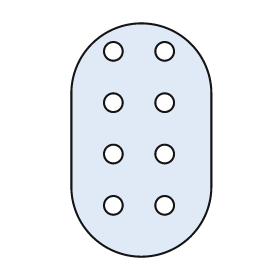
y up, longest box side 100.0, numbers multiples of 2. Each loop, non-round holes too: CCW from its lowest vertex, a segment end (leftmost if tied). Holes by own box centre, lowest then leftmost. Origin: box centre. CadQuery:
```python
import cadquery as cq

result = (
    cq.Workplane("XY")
    .moveTo(-30.0, -20.0)
    .threePointArc((0.0, -50.0), (30.0, -20.0))
    .lineTo(30.0, 20.0)
    .threePointArc((0.0, 50.0), (-30.0, 20.0))
    .close()
    .moveTo(-12.0, -28.0)
    .circle(4.0)
    .moveTo(10.0, -28.0)
    .circle(4.0)
    .moveTo(-12.0, -6.0)
    .circle(4.0)
    .moveTo(10.0, -6.0)
    .circle(4.0)
    .moveTo(-12.0, 16.0)
    .circle(4.0)
    .moveTo(10.0, 16.0)
    .circle(4.0)
    .moveTo(-12.0, 38.0)
    .circle(4.0)
    .moveTo(10.0, 38.0)
    .circle(4.0)
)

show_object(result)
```